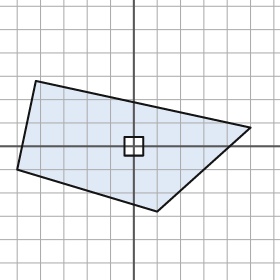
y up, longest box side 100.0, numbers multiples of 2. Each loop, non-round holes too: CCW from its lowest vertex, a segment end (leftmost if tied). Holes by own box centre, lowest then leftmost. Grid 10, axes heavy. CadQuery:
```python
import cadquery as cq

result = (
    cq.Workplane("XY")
    .moveTo(10.0, -28.0)
    .lineTo(50.0, 8.0)
    .lineTo(-42.0, 28.0)
    .lineTo(-50.0, -10.0)
    .close()
    .moveTo(-4.0, -4.0)
    .lineTo(4.0, -4.0)
    .lineTo(4.0, 4.0)
    .lineTo(-4.0, 4.0)
    .close()
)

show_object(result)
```